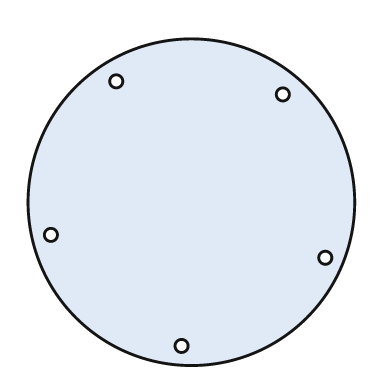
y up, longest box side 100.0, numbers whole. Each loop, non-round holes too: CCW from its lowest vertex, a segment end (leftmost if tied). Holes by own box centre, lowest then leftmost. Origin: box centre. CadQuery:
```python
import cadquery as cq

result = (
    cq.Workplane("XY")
    .moveTo(0.0, 0.0)
    .circle(50.0)
    .moveTo(-3.0, -44.0)
    .circle(2.0)
    .moveTo(41.0, -17.0)
    .circle(2.0)
    .moveTo(-43.0, -10.0)
    .circle(2.0)
    .moveTo(28.0, 33.0)
    .circle(2.0)
    .moveTo(-23.0, 37.0)
    .circle(2.0)
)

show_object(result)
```